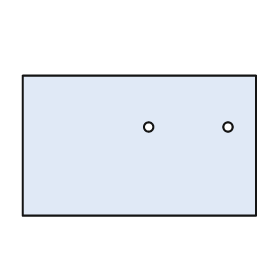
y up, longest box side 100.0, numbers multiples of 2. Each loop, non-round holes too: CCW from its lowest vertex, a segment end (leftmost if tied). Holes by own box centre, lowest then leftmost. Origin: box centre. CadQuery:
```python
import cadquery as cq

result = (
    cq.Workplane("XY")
    .moveTo(-50.0, -30.0)
    .lineTo(50.0, -30.0)
    .lineTo(50.0, 30.0)
    .lineTo(-50.0, 30.0)
    .close()
    .moveTo(4.0, 8.0)
    .circle(2.0)
    .moveTo(38.0, 8.0)
    .circle(2.0)
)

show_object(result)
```